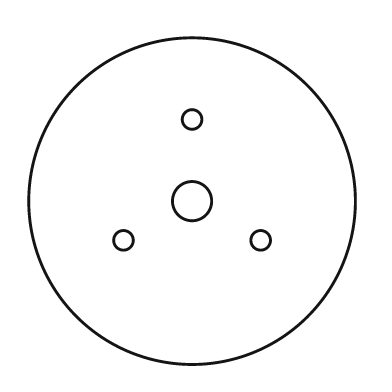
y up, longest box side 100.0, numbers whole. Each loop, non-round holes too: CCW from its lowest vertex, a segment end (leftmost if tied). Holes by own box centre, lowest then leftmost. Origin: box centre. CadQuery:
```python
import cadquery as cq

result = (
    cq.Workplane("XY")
    .moveTo(0.0, 0.0)
    .circle(50.0)
    .moveTo(-21.0, -12.0)
    .circle(3.0)
    .moveTo(21.0, -12.0)
    .circle(3.0)
    .moveTo(0.0, 0.0)
    .circle(6.0)
    .moveTo(0.0, 25.0)
    .circle(3.0)
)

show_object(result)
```